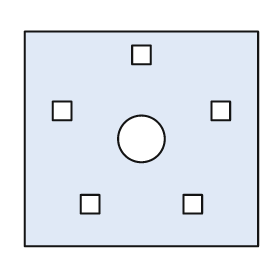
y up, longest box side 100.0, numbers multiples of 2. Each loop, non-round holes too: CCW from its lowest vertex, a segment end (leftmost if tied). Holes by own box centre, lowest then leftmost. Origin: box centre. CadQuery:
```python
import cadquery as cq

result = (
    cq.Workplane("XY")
    .moveTo(-50.0, -46.0)
    .lineTo(50.0, -46.0)
    .lineTo(50.0, 46.0)
    .lineTo(-50.0, 46.0)
    .close()
    .moveTo(-26.0, -32.0)
    .lineTo(-18.0, -32.0)
    .lineTo(-18.0, -24.0)
    .lineTo(-26.0, -24.0)
    .close()
    .moveTo(18.0, -32.0)
    .lineTo(26.0, -32.0)
    .lineTo(26.0, -24.0)
    .lineTo(18.0, -24.0)
    .close()
    .moveTo(0.0, 0.0)
    .circle(10.0)
    .moveTo(-38.0, 8.0)
    .lineTo(-30.0, 8.0)
    .lineTo(-30.0, 16.0)
    .lineTo(-38.0, 16.0)
    .close()
    .moveTo(30.0, 8.0)
    .lineTo(38.0, 8.0)
    .lineTo(38.0, 16.0)
    .lineTo(30.0, 16.0)
    .close()
    .moveTo(-4.0, 32.0)
    .lineTo(4.0, 32.0)
    .lineTo(4.0, 40.0)
    .lineTo(-4.0, 40.0)
    .close()
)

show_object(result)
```